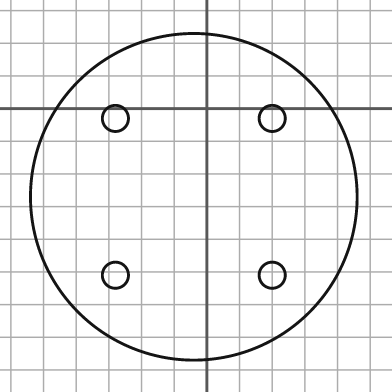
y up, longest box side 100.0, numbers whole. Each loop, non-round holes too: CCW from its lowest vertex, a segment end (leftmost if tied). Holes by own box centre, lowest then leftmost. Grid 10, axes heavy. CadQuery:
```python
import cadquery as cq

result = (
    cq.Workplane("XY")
    .moveTo(-4.0, -27.0)
    .circle(50.0)
    .moveTo(-28.0, -51.0)
    .circle(4.0)
    .moveTo(20.0, -51.0)
    .circle(4.0)
    .moveTo(-28.0, -3.0)
    .circle(4.0)
    .moveTo(20.0, -3.0)
    .circle(4.0)
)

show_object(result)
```